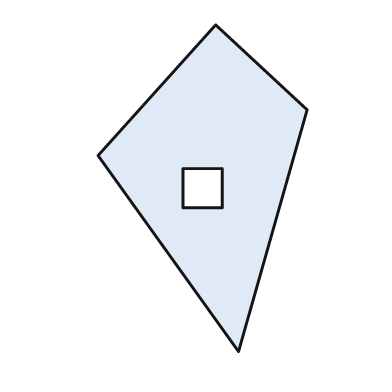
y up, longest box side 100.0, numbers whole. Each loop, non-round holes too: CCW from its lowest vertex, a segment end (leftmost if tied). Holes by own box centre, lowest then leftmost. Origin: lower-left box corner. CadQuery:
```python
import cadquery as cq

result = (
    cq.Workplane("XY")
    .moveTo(43.0, 0.0)
    .lineTo(64.0, 74.0)
    .lineTo(36.0, 100.0)
    .lineTo(0.0, 60.0)
    .close()
    .moveTo(26.0, 44.0)
    .lineTo(38.0, 44.0)
    .lineTo(38.0, 56.0)
    .lineTo(26.0, 56.0)
    .close()
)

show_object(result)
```